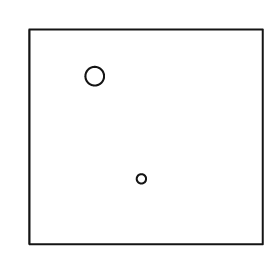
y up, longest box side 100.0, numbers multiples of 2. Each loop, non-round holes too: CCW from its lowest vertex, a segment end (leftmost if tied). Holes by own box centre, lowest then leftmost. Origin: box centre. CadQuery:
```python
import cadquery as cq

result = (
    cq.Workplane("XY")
    .moveTo(-50.0, -46.0)
    .lineTo(50.0, -46.0)
    .lineTo(50.0, 46.0)
    .lineTo(-50.0, 46.0)
    .close()
    .moveTo(-2.0, -18.0)
    .circle(2.0)
    .moveTo(-22.0, 26.0)
    .circle(4.0)
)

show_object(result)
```